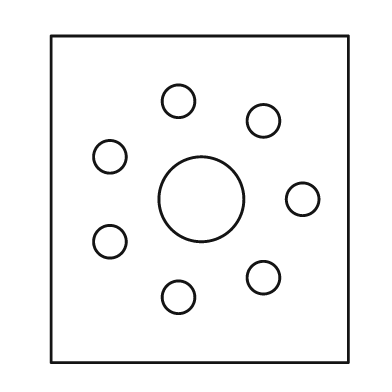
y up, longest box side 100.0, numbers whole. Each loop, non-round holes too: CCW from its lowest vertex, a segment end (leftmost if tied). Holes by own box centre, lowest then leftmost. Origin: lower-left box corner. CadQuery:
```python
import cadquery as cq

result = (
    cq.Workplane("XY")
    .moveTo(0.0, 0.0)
    .lineTo(91.0, 0.0)
    .lineTo(91.0, 100.0)
    .lineTo(0.0, 100.0)
    .close()
    .moveTo(39.0, 20.0)
    .circle(5.0)
    .moveTo(65.0, 26.0)
    .circle(5.0)
    .moveTo(18.0, 37.0)
    .circle(5.0)
    .moveTo(46.0, 50.0)
    .circle(13.0)
    .moveTo(77.0, 50.0)
    .circle(5.0)
    .moveTo(18.0, 63.0)
    .circle(5.0)
    .moveTo(65.0, 74.0)
    .circle(5.0)
    .moveTo(39.0, 80.0)
    .circle(5.0)
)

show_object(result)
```